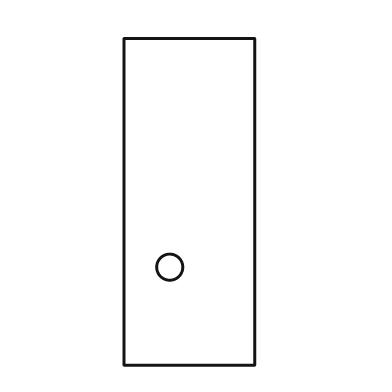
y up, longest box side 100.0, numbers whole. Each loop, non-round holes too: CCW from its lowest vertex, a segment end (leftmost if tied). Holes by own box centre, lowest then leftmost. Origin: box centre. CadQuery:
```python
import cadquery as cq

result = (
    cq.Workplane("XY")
    .moveTo(-20.0, -50.0)
    .lineTo(20.0, -50.0)
    .lineTo(20.0, 50.0)
    .lineTo(-20.0, 50.0)
    .close()
    .moveTo(-6.0, -20.0)
    .circle(4.0)
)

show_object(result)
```